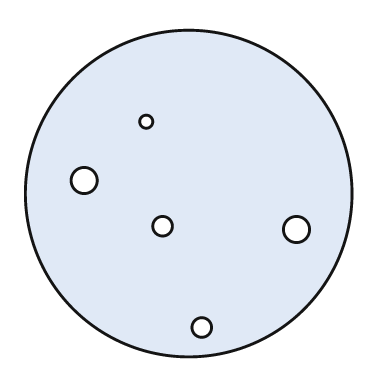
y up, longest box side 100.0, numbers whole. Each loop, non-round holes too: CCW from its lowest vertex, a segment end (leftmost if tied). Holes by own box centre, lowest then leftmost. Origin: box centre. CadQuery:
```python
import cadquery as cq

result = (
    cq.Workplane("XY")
    .moveTo(0.0, 0.0)
    .circle(50.0)
    .moveTo(4.0, -41.0)
    .circle(3.0)
    .moveTo(33.0, -11.0)
    .circle(4.0)
    .moveTo(-8.0, -10.0)
    .circle(3.0)
    .moveTo(-32.0, 4.0)
    .circle(4.0)
    .moveTo(-13.0, 22.0)
    .circle(2.0)
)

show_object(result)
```